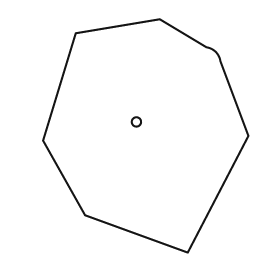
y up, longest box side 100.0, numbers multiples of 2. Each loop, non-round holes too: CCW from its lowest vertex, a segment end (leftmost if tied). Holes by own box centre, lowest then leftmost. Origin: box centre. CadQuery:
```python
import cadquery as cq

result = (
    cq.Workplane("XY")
    .moveTo(18.0, -50.0)
    .lineTo(44.0, 0.0)
    .lineTo(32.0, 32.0)
    .threePointArc((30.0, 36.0), (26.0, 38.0))
    .lineTo(6.0, 50.0)
    .lineTo(-30.0, 44.0)
    .lineTo(-44.0, -2.0)
    .lineTo(-26.0, -34.0)
    .close()
    .moveTo(-4.0, 6.0)
    .circle(2.0)
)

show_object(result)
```